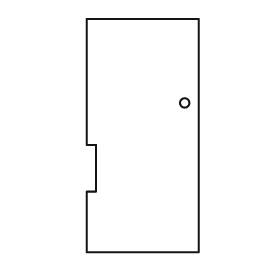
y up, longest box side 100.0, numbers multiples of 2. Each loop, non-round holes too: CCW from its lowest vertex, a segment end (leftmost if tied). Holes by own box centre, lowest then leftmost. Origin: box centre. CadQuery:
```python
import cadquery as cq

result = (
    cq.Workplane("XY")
    .moveTo(-24.0, -50.0)
    .lineTo(24.0, -50.0)
    .lineTo(24.0, 50.0)
    .lineTo(-24.0, 50.0)
    .lineTo(-24.0, -4.0)
    .lineTo(-20.0, -4.0)
    .lineTo(-20.0, -24.0)
    .lineTo(-24.0, -24.0)
    .close()
    .moveTo(18.0, 14.0)
    .circle(2.0)
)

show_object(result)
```